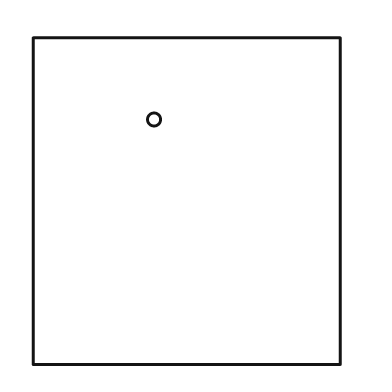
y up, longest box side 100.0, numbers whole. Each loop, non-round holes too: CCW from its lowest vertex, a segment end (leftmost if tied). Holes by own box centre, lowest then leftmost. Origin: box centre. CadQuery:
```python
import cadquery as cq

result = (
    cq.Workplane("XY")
    .moveTo(-47.0, -50.0)
    .lineTo(47.0, -50.0)
    .lineTo(47.0, 50.0)
    .lineTo(-47.0, 50.0)
    .close()
    .moveTo(-10.0, 25.0)
    .circle(2.0)
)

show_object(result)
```